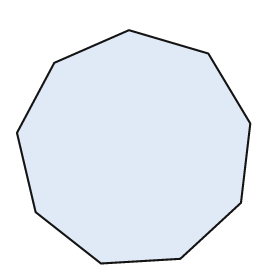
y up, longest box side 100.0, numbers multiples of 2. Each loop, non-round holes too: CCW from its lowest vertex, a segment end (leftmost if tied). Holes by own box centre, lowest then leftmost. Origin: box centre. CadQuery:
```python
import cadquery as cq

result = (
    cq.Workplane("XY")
    .moveTo(-14.0, -50.0)
    .lineTo(20.0, -48.0)
    .lineTo(46.0, -24.0)
    .lineTo(50.0, 10.0)
    .lineTo(32.0, 40.0)
    .lineTo(-2.0, 50.0)
    .lineTo(-34.0, 36.0)
    .lineTo(-50.0, 6.0)
    .lineTo(-42.0, -28.0)
    .close()
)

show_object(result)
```